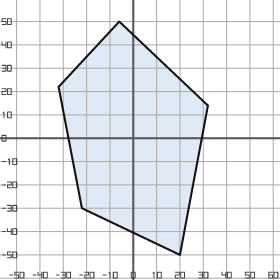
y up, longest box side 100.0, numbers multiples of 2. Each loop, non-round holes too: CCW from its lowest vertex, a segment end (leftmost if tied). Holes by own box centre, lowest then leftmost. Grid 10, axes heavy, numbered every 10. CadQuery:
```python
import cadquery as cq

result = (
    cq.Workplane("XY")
    .moveTo(20.0, -50.0)
    .lineTo(32.0, 14.0)
    .lineTo(-6.0, 50.0)
    .lineTo(-32.0, 22.0)
    .lineTo(-22.0, -30.0)
    .close()
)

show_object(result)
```